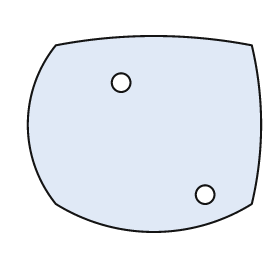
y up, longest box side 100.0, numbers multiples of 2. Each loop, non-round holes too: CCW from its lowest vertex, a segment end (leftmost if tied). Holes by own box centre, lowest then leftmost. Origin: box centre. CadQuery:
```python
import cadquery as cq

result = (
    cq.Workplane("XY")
    .moveTo(-38.0, -30.0)
    .threePointArc((4.0, -42.0), (46.0, -30.0))
    .threePointArc((50.0, 4.0), (46.0, 38.0))
    .threePointArc((4.0, 42.0), (-38.0, 38.0))
    .threePointArc((-50.0, 4.0), (-38.0, -30.0))
    .close()
    .moveTo(26.0, -26.0)
    .circle(4.0)
    .moveTo(-10.0, 22.0)
    .circle(4.0)
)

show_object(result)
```